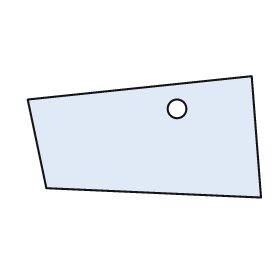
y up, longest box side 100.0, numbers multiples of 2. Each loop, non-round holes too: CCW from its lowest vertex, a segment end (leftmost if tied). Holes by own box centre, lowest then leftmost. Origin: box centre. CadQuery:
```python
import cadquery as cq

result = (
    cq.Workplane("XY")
    .moveTo(50.0, -26.0)
    .lineTo(46.0, 26.0)
    .lineTo(-50.0, 16.0)
    .lineTo(-42.0, -22.0)
    .close()
    .moveTo(14.0, 12.0)
    .circle(4.0)
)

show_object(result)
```